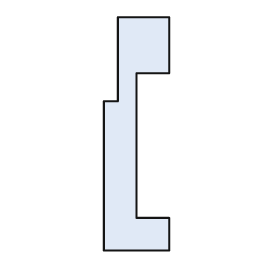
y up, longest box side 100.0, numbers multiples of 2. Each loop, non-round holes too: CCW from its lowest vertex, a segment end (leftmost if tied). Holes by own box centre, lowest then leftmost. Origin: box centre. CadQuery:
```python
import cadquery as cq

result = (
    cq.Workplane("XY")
    .moveTo(-14.0, -50.0)
    .lineTo(14.0, -50.0)
    .lineTo(14.0, -36.0)
    .lineTo(0.0, -36.0)
    .lineTo(0.0, 26.0)
    .lineTo(14.0, 26.0)
    .lineTo(14.0, 50.0)
    .lineTo(-8.0, 50.0)
    .lineTo(-8.0, 14.0)
    .lineTo(-14.0, 14.0)
    .close()
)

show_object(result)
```